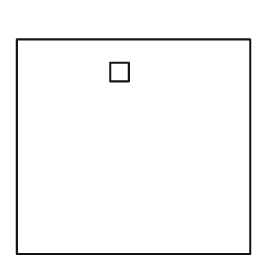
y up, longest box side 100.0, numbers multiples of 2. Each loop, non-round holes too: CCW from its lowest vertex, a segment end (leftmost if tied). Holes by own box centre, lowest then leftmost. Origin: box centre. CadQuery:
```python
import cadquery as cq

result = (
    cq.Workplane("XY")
    .moveTo(-50.0, -46.0)
    .lineTo(50.0, -46.0)
    .lineTo(50.0, 46.0)
    .lineTo(-50.0, 46.0)
    .close()
    .moveTo(-10.0, 28.0)
    .lineTo(-2.0, 28.0)
    .lineTo(-2.0, 36.0)
    .lineTo(-10.0, 36.0)
    .close()
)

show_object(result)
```